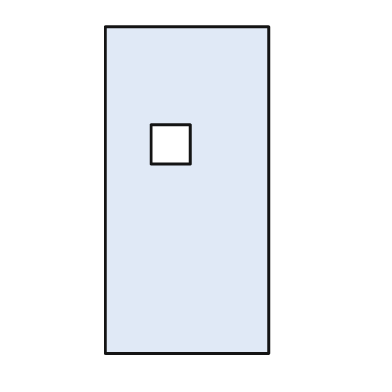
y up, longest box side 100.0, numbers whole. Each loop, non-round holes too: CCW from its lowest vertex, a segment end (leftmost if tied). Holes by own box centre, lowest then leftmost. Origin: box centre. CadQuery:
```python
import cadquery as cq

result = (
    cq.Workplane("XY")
    .moveTo(-25.0, -50.0)
    .lineTo(25.0, -50.0)
    .lineTo(25.0, 50.0)
    .lineTo(-25.0, 50.0)
    .close()
    .moveTo(-11.0, 8.0)
    .lineTo(1.0, 8.0)
    .lineTo(1.0, 20.0)
    .lineTo(-11.0, 20.0)
    .close()
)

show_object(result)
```